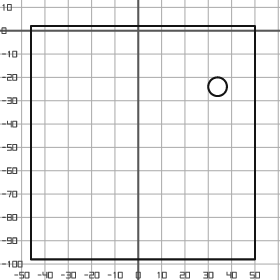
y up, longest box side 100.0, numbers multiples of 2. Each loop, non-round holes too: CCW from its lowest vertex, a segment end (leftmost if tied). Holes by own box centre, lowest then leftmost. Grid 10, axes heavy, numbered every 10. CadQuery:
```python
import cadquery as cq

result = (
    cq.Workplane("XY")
    .moveTo(-46.0, -98.0)
    .lineTo(50.0, -98.0)
    .lineTo(50.0, 2.0)
    .lineTo(-46.0, 2.0)
    .close()
    .moveTo(34.0, -24.0)
    .circle(4.0)
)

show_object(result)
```